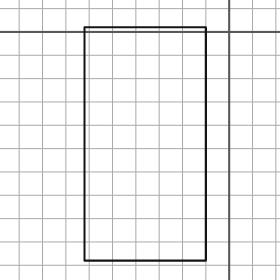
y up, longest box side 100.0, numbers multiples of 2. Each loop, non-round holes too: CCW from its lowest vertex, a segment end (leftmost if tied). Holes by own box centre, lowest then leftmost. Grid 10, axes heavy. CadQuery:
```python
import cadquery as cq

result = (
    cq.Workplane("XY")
    .moveTo(-62.0, -98.0)
    .lineTo(-10.0, -98.0)
    .lineTo(-10.0, 2.0)
    .lineTo(-62.0, 2.0)
    .close()
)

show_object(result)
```